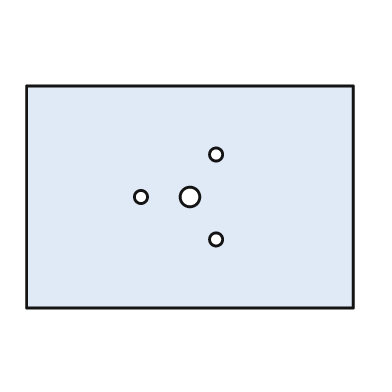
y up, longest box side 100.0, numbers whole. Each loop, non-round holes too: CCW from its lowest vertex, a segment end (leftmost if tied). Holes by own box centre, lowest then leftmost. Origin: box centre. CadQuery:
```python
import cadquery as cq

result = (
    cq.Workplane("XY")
    .moveTo(-50.0, -34.0)
    .lineTo(50.0, -34.0)
    .lineTo(50.0, 34.0)
    .lineTo(-50.0, 34.0)
    .close()
    .moveTo(8.0, -13.0)
    .circle(2.0)
    .moveTo(-15.0, 0.0)
    .circle(2.0)
    .moveTo(0.0, 0.0)
    .circle(3.0)
    .moveTo(8.0, 13.0)
    .circle(2.0)
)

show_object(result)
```